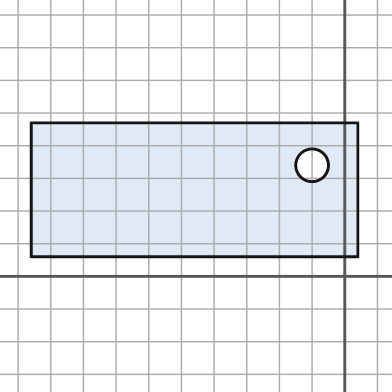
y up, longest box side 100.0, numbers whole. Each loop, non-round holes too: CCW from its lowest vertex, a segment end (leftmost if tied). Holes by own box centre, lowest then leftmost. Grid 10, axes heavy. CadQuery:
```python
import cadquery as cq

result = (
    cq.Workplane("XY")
    .moveTo(-96.0, 6.0)
    .lineTo(4.0, 6.0)
    .lineTo(4.0, 47.0)
    .lineTo(-96.0, 47.0)
    .close()
    .moveTo(-10.0, 34.0)
    .circle(5.0)
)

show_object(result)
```